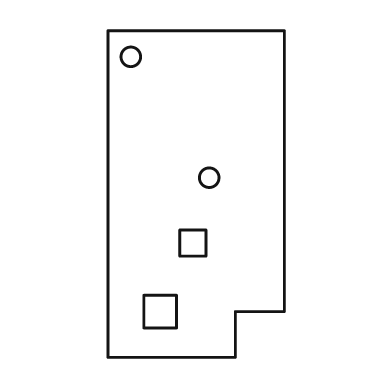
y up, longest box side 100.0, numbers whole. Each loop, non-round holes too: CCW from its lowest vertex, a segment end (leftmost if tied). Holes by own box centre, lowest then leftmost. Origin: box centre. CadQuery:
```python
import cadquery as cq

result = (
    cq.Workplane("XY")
    .moveTo(-27.0, -50.0)
    .lineTo(12.0, -50.0)
    .lineTo(12.0, -36.0)
    .lineTo(27.0, -36.0)
    .lineTo(27.0, 50.0)
    .lineTo(-27.0, 50.0)
    .close()
    .moveTo(-16.0, -41.0)
    .lineTo(-6.0, -41.0)
    .lineTo(-6.0, -31.0)
    .lineTo(-16.0, -31.0)
    .close()
    .moveTo(-5.0, -19.0)
    .lineTo(3.0, -19.0)
    .lineTo(3.0, -11.0)
    .lineTo(-5.0, -11.0)
    .close()
    .moveTo(4.0, 5.0)
    .circle(3.0)
    .moveTo(-20.0, 42.0)
    .circle(3.0)
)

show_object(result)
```